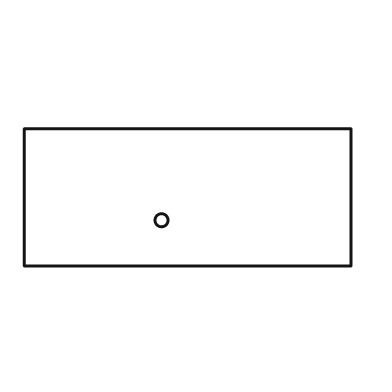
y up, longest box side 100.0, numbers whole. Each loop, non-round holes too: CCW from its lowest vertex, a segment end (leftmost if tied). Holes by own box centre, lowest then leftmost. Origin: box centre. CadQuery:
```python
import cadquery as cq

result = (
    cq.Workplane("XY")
    .moveTo(-50.0, -21.0)
    .lineTo(50.0, -21.0)
    .lineTo(50.0, 21.0)
    .lineTo(-50.0, 21.0)
    .close()
    .moveTo(-8.0, -7.0)
    .circle(2.0)
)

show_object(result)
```